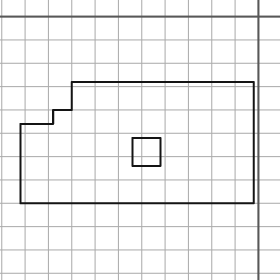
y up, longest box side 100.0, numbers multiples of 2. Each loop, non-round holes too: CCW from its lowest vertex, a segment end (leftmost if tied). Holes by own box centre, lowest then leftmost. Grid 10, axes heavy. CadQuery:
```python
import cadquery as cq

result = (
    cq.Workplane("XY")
    .moveTo(-102.0, -80.0)
    .lineTo(-2.0, -80.0)
    .lineTo(-2.0, -28.0)
    .lineTo(-80.0, -28.0)
    .lineTo(-80.0, -40.0)
    .lineTo(-88.0, -40.0)
    .lineTo(-88.0, -46.0)
    .lineTo(-102.0, -46.0)
    .close()
    .moveTo(-54.0, -64.0)
    .lineTo(-42.0, -64.0)
    .lineTo(-42.0, -52.0)
    .lineTo(-54.0, -52.0)
    .close()
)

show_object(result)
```